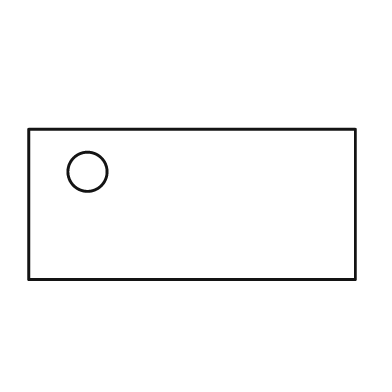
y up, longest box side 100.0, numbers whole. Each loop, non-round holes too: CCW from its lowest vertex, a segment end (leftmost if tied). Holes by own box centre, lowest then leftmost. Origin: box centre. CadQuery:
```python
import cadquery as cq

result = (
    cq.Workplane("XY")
    .moveTo(-50.0, -23.0)
    .lineTo(50.0, -23.0)
    .lineTo(50.0, 23.0)
    .lineTo(-50.0, 23.0)
    .close()
    .moveTo(-32.0, 10.0)
    .circle(6.0)
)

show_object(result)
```